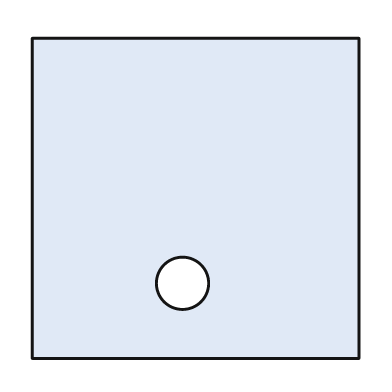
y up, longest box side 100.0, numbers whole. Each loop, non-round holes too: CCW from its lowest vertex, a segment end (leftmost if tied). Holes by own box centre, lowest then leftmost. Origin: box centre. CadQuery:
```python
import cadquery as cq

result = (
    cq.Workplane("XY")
    .moveTo(-50.0, -49.0)
    .lineTo(50.0, -49.0)
    .lineTo(50.0, 49.0)
    .lineTo(-50.0, 49.0)
    .close()
    .moveTo(-4.0, -26.0)
    .circle(8.0)
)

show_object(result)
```